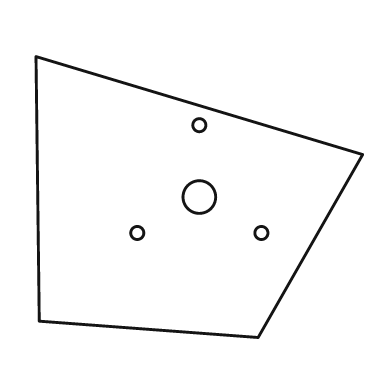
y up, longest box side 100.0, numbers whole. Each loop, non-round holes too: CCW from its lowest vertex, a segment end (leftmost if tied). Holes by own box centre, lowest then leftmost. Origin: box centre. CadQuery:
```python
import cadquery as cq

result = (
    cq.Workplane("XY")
    .moveTo(18.0, -43.0)
    .lineTo(50.0, 13.0)
    .lineTo(-50.0, 43.0)
    .lineTo(-49.0, -38.0)
    .close()
    .moveTo(-19.0, -11.0)
    .circle(2.0)
    .moveTo(19.0, -11.0)
    .circle(2.0)
    .moveTo(0.0, 0.0)
    .circle(5.0)
    .moveTo(0.0, 22.0)
    .circle(2.0)
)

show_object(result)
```